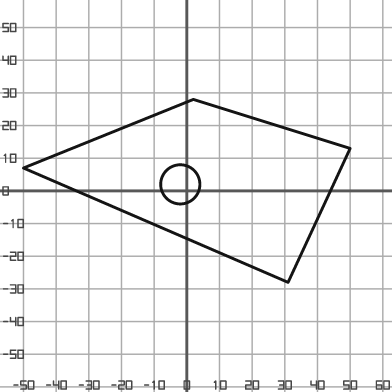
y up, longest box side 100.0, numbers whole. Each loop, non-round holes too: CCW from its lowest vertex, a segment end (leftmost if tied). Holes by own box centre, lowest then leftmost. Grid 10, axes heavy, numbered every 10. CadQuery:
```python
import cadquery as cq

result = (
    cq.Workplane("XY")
    .moveTo(31.0, -28.0)
    .lineTo(50.0, 13.0)
    .lineTo(2.0, 28.0)
    .lineTo(-50.0, 7.0)
    .close()
    .moveTo(-2.0, 2.0)
    .circle(6.0)
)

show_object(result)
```